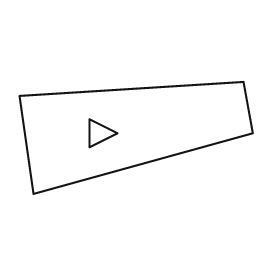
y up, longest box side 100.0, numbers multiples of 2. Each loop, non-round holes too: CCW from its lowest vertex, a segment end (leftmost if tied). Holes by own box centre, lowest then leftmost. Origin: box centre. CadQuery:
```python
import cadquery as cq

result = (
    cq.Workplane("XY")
    .moveTo(-44.0, -24.0)
    .lineTo(50.0, 2.0)
    .lineTo(46.0, 24.0)
    .lineTo(-50.0, 18.0)
    .close()
    .moveTo(-20.0, -4.0)
    .lineTo(-8.0, 2.0)
    .lineTo(-20.0, 8.0)
    .close()
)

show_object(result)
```